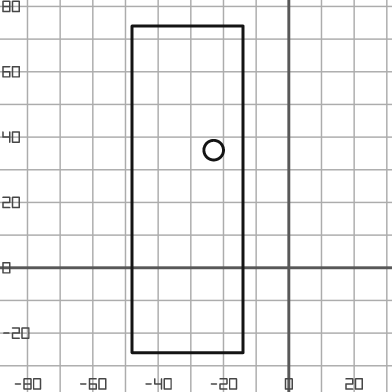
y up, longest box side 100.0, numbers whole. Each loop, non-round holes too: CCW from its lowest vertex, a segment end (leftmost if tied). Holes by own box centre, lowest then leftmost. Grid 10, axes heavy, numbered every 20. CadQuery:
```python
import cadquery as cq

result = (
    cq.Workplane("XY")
    .moveTo(-48.0, -26.0)
    .lineTo(-14.0, -26.0)
    .lineTo(-14.0, 74.0)
    .lineTo(-48.0, 74.0)
    .close()
    .moveTo(-23.0, 36.0)
    .circle(3.0)
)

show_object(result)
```